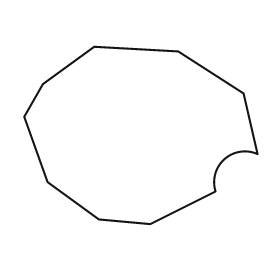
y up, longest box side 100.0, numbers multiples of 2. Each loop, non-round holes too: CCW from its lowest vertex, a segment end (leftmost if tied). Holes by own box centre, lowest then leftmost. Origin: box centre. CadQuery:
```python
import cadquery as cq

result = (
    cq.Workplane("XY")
    .moveTo(4.0, -38.0)
    .lineTo(32.0, -24.0)
    .threePointArc((36.0, -10.0), (50.0, -8.0))
    .lineTo(44.0, 18.0)
    .lineTo(16.0, 36.0)
    .lineTo(-20.0, 38.0)
    .lineTo(-42.0, 22.0)
    .lineTo(-50.0, 8.0)
    .lineTo(-40.0, -20.0)
    .lineTo(-18.0, -36.0)
    .close()
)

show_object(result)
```